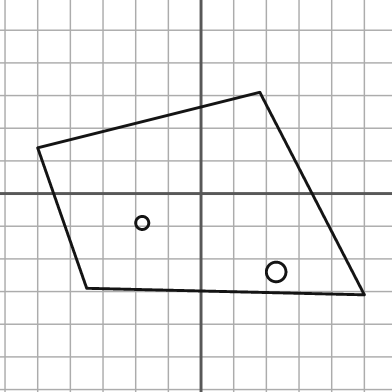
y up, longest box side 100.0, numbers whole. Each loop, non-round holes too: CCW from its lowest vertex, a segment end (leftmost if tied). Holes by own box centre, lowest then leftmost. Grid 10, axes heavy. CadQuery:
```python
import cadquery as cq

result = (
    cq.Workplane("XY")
    .moveTo(50.0, -31.0)
    .lineTo(18.0, 31.0)
    .lineTo(-50.0, 14.0)
    .lineTo(-35.0, -29.0)
    .close()
    .moveTo(23.0, -24.0)
    .circle(3.0)
    .moveTo(-18.0, -9.0)
    .circle(2.0)
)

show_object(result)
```